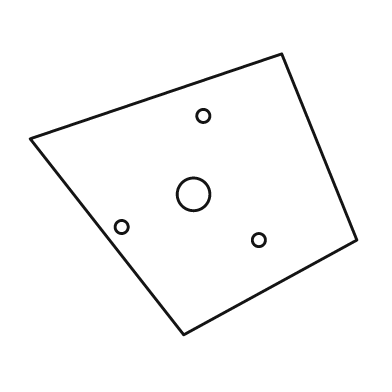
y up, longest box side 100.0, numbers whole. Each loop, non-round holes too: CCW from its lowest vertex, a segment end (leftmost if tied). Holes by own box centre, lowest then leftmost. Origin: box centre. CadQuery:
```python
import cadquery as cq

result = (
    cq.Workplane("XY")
    .moveTo(-3.0, -43.0)
    .lineTo(50.0, -14.0)
    .lineTo(27.0, 43.0)
    .lineTo(-50.0, 17.0)
    .close()
    .moveTo(20.0, -14.0)
    .circle(2.0)
    .moveTo(-22.0, -10.0)
    .circle(2.0)
    .moveTo(0.0, 0.0)
    .circle(5.0)
    .moveTo(3.0, 24.0)
    .circle(2.0)
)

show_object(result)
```